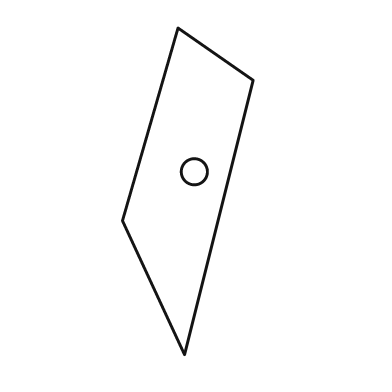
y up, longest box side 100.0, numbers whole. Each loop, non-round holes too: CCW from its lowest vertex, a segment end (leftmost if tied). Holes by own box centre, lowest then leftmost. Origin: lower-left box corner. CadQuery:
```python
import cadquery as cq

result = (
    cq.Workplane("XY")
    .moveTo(19.0, 0.0)
    .lineTo(40.0, 84.0)
    .lineTo(17.0, 100.0)
    .lineTo(0.0, 41.0)
    .close()
    .moveTo(22.0, 56.0)
    .circle(4.0)
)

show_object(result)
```